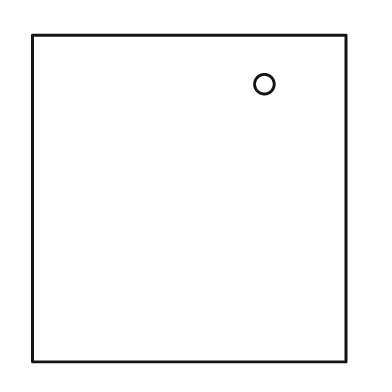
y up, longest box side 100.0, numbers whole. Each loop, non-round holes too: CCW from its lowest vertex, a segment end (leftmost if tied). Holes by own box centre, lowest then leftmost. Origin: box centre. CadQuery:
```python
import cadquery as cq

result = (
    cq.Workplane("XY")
    .moveTo(-48.0, -50.0)
    .lineTo(48.0, -50.0)
    .lineTo(48.0, 50.0)
    .lineTo(-48.0, 50.0)
    .close()
    .moveTo(23.0, 35.0)
    .circle(3.0)
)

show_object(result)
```